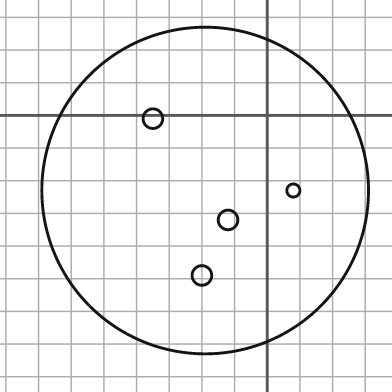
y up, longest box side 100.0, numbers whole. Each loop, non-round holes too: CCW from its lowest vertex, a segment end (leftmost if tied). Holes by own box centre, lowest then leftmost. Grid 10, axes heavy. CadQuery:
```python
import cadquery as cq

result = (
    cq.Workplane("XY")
    .moveTo(-19.0, -23.0)
    .circle(50.0)
    .moveTo(-20.0, -49.0)
    .circle(3.0)
    .moveTo(-12.0, -32.0)
    .circle(3.0)
    .moveTo(8.0, -23.0)
    .circle(2.0)
    .moveTo(-35.0, -1.0)
    .circle(3.0)
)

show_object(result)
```